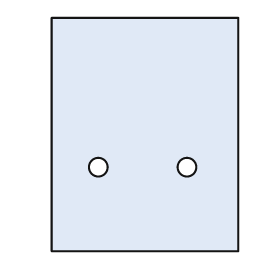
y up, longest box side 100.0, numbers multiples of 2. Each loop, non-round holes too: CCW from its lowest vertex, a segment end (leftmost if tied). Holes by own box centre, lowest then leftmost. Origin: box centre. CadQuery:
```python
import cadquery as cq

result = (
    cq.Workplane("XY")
    .moveTo(-40.0, -50.0)
    .lineTo(40.0, -50.0)
    .lineTo(40.0, 50.0)
    .lineTo(-40.0, 50.0)
    .close()
    .moveTo(-20.0, -14.0)
    .circle(4.0)
    .moveTo(18.0, -14.0)
    .circle(4.0)
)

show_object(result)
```